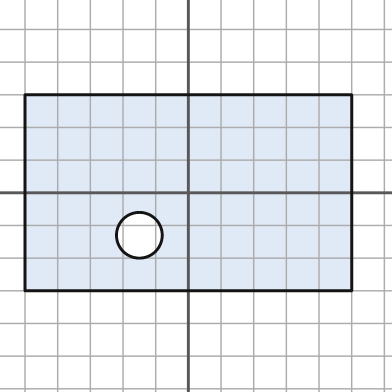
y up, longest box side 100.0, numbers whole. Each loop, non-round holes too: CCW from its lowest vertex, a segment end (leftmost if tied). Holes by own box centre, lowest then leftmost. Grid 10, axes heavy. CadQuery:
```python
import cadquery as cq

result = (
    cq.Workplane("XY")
    .moveTo(-50.0, -30.0)
    .lineTo(50.0, -30.0)
    .lineTo(50.0, 30.0)
    .lineTo(-50.0, 30.0)
    .close()
    .moveTo(-15.0, -13.0)
    .circle(7.0)
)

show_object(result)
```